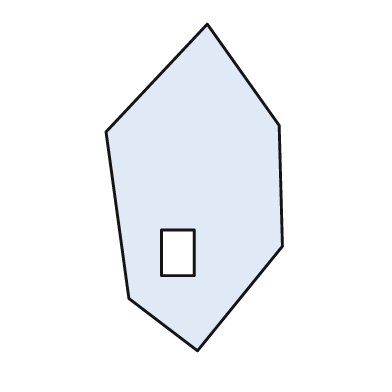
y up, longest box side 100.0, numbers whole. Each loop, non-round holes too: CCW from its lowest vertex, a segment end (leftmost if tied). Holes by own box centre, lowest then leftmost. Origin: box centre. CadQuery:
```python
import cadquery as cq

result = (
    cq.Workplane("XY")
    .moveTo(1.0, -50.0)
    .lineTo(27.0, -18.0)
    .lineTo(26.0, 19.0)
    .lineTo(4.0, 50.0)
    .lineTo(-27.0, 17.0)
    .lineTo(-20.0, -34.0)
    .close()
    .moveTo(-10.0, -27.0)
    .lineTo(0.0, -27.0)
    .lineTo(0.0, -13.0)
    .lineTo(-10.0, -13.0)
    .close()
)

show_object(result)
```